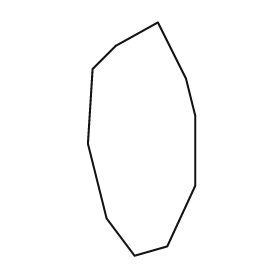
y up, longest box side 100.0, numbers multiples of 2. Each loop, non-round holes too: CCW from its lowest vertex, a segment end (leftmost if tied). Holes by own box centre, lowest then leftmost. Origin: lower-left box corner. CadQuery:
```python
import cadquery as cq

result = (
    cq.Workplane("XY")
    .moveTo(20.0, 0.0)
    .lineTo(34.0, 4.0)
    .lineTo(46.0, 30.0)
    .lineTo(46.0, 60.0)
    .lineTo(42.0, 76.0)
    .lineTo(30.0, 100.0)
    .lineTo(12.0, 90.0)
    .lineTo(2.0, 80.0)
    .lineTo(0.0, 48.0)
    .lineTo(8.0, 16.0)
    .close()
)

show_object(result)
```